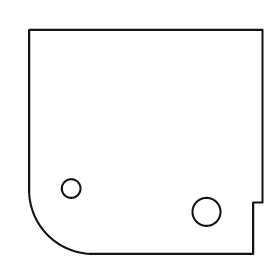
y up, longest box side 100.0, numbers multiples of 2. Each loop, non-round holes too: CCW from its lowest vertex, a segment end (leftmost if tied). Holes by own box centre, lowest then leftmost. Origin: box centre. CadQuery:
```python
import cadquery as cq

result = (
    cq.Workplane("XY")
    .moveTo(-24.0, -48.0)
    .lineTo(46.0, -48.0)
    .lineTo(46.0, -26.0)
    .lineTo(50.0, -26.0)
    .lineTo(50.0, 48.0)
    .lineTo(-50.0, 48.0)
    .lineTo(-50.0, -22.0)
    .threePointArc((-42.0, -40.0), (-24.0, -48.0))
    .close()
    .moveTo(26.0, -30.0)
    .circle(6.0)
    .moveTo(-32.0, -20.0)
    .circle(4.0)
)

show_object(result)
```